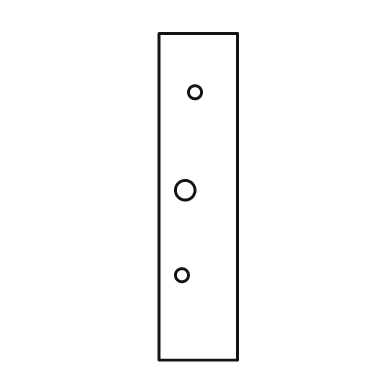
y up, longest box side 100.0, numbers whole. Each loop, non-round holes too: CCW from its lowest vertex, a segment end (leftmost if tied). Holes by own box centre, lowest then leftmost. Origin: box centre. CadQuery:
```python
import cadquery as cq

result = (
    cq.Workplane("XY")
    .moveTo(-12.0, -50.0)
    .lineTo(12.0, -50.0)
    .lineTo(12.0, 50.0)
    .lineTo(-12.0, 50.0)
    .close()
    .moveTo(-5.0, -24.0)
    .circle(2.0)
    .moveTo(-4.0, 2.0)
    .circle(3.0)
    .moveTo(-1.0, 32.0)
    .circle(2.0)
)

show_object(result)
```